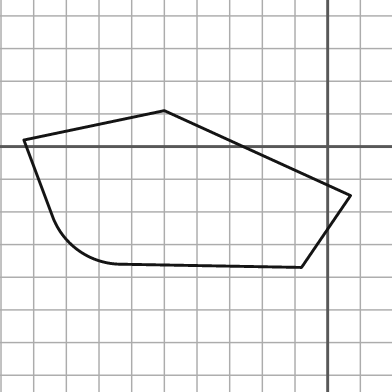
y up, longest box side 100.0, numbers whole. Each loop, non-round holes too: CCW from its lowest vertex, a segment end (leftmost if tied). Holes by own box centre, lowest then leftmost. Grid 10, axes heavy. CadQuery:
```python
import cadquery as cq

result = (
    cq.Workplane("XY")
    .moveTo(-8.0, -37.0)
    .lineTo(7.0, -15.0)
    .lineTo(-50.0, 11.0)
    .lineTo(-93.0, 2.0)
    .lineTo(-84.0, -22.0)
    .threePointArc((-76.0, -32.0), (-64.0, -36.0))
    .close()
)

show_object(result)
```